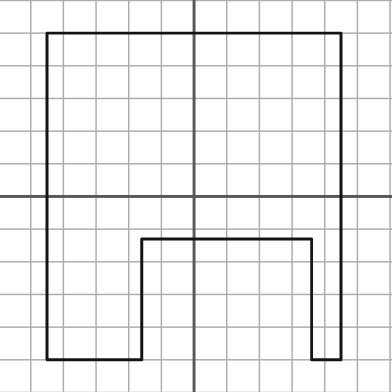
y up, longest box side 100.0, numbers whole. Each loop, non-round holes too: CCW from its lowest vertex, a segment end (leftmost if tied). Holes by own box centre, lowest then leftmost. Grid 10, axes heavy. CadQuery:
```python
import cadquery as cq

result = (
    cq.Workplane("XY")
    .moveTo(-45.0, -50.0)
    .lineTo(-16.0, -50.0)
    .lineTo(-16.0, -13.0)
    .lineTo(36.0, -13.0)
    .lineTo(36.0, -50.0)
    .lineTo(45.0, -50.0)
    .lineTo(45.0, 50.0)
    .lineTo(-45.0, 50.0)
    .close()
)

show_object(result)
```